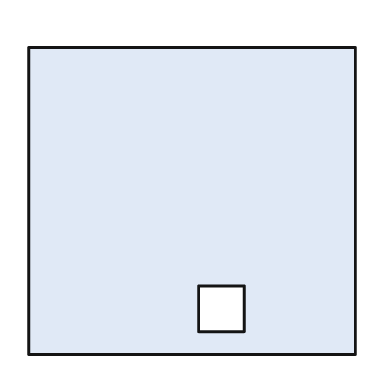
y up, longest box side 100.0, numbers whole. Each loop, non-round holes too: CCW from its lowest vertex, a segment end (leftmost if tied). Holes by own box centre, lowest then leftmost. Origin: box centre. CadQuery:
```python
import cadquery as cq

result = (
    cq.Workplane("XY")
    .moveTo(-50.0, -47.0)
    .lineTo(50.0, -47.0)
    .lineTo(50.0, 47.0)
    .lineTo(-50.0, 47.0)
    .close()
    .moveTo(2.0, -40.0)
    .lineTo(16.0, -40.0)
    .lineTo(16.0, -26.0)
    .lineTo(2.0, -26.0)
    .close()
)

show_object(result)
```